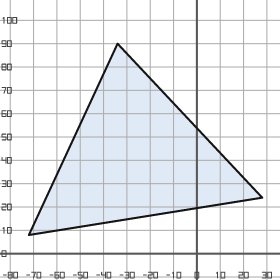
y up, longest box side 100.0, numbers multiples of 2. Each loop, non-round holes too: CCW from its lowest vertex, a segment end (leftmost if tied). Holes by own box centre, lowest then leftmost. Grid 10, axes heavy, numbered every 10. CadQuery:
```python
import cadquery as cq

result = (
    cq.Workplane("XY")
    .moveTo(-72.0, 8.0)
    .lineTo(28.0, 24.0)
    .lineTo(-34.0, 90.0)
    .close()
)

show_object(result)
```